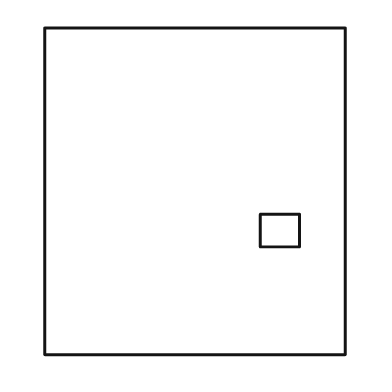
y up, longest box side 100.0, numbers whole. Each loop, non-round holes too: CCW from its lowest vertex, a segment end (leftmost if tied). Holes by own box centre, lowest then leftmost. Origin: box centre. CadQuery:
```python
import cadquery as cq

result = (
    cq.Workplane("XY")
    .moveTo(-46.0, -50.0)
    .lineTo(46.0, -50.0)
    .lineTo(46.0, 50.0)
    .lineTo(-46.0, 50.0)
    .close()
    .moveTo(20.0, -17.0)
    .lineTo(32.0, -17.0)
    .lineTo(32.0, -7.0)
    .lineTo(20.0, -7.0)
    .close()
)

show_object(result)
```